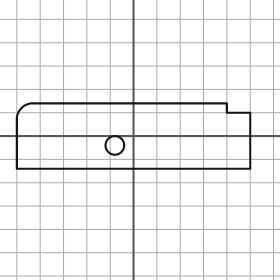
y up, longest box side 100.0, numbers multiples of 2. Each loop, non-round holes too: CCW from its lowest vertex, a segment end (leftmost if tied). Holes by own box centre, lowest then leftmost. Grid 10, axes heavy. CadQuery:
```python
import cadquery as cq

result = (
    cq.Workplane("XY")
    .moveTo(-50.0, -14.0)
    .lineTo(50.0, -14.0)
    .lineTo(50.0, 10.0)
    .lineTo(40.0, 10.0)
    .lineTo(40.0, 14.0)
    .lineTo(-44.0, 14.0)
    .threePointArc((-48.0, 12.0), (-50.0, 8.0))
    .close()
    .moveTo(-8.0, -4.0)
    .circle(4.0)
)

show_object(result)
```